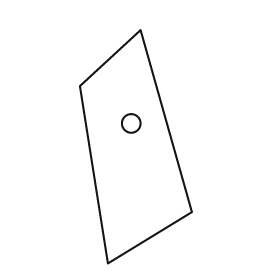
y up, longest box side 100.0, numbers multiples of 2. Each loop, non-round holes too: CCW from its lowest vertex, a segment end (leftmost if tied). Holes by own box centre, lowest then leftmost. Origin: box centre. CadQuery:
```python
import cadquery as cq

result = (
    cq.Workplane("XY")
    .moveTo(-12.0, -50.0)
    .lineTo(24.0, -28.0)
    .lineTo(2.0, 50.0)
    .lineTo(-24.0, 26.0)
    .close()
    .moveTo(-2.0, 10.0)
    .circle(4.0)
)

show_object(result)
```